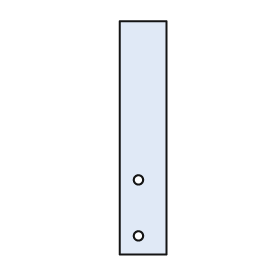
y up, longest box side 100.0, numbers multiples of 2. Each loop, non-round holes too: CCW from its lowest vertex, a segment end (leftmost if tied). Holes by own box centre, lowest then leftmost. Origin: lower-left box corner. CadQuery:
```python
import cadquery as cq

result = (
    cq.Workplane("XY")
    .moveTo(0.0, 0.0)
    .lineTo(20.0, 0.0)
    .lineTo(20.0, 100.0)
    .lineTo(0.0, 100.0)
    .close()
    .moveTo(8.0, 8.0)
    .circle(2.0)
    .moveTo(8.0, 32.0)
    .circle(2.0)
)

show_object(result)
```